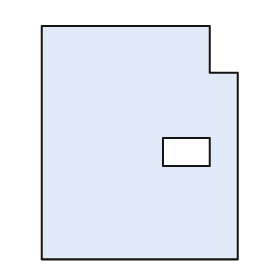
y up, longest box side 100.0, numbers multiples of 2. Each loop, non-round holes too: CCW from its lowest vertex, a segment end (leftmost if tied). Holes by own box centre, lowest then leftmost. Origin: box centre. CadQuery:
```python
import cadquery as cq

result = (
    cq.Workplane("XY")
    .moveTo(-42.0, -50.0)
    .lineTo(42.0, -50.0)
    .lineTo(42.0, 30.0)
    .lineTo(30.0, 30.0)
    .lineTo(30.0, 50.0)
    .lineTo(-42.0, 50.0)
    .close()
    .moveTo(10.0, -10.0)
    .lineTo(30.0, -10.0)
    .lineTo(30.0, 2.0)
    .lineTo(10.0, 2.0)
    .close()
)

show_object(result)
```